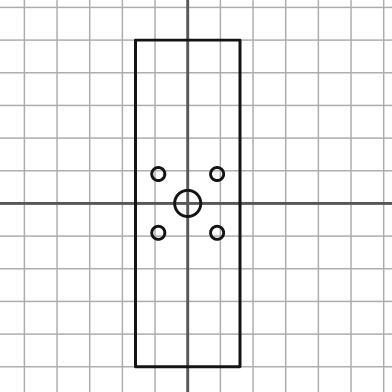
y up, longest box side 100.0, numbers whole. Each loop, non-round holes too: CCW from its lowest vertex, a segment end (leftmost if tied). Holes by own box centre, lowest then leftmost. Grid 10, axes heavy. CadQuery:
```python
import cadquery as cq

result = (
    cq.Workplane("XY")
    .moveTo(-16.0, -50.0)
    .lineTo(16.0, -50.0)
    .lineTo(16.0, 50.0)
    .lineTo(-16.0, 50.0)
    .close()
    .moveTo(-9.0, -9.0)
    .circle(2.0)
    .moveTo(9.0, -9.0)
    .circle(2.0)
    .moveTo(0.0, 0.0)
    .circle(4.0)
    .moveTo(-9.0, 9.0)
    .circle(2.0)
    .moveTo(9.0, 9.0)
    .circle(2.0)
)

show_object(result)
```